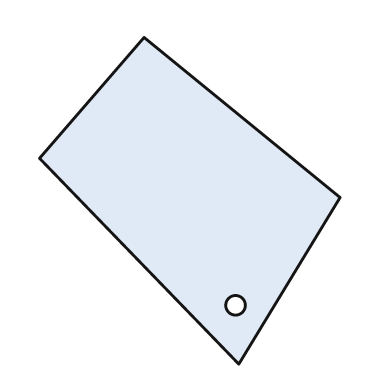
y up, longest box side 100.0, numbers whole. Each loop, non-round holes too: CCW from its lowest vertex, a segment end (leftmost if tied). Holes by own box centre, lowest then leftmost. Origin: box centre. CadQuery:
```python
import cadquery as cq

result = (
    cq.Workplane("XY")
    .moveTo(15.0, -50.0)
    .lineTo(46.0, 1.0)
    .lineTo(-14.0, 50.0)
    .lineTo(-46.0, 13.0)
    .close()
    .moveTo(14.0, -32.0)
    .circle(3.0)
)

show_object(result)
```